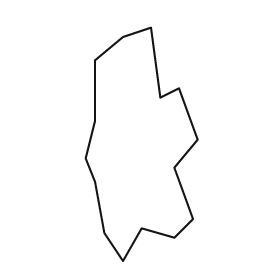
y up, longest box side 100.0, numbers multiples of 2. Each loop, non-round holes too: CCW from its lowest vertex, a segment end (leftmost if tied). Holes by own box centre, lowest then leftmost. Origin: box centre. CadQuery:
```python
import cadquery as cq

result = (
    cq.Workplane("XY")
    .moveTo(-8.0, -50.0)
    .lineTo(0.0, -36.0)
    .lineTo(14.0, -40.0)
    .lineTo(22.0, -32.0)
    .lineTo(14.0, -10.0)
    .lineTo(24.0, 2.0)
    .lineTo(16.0, 24.0)
    .lineTo(8.0, 20.0)
    .lineTo(4.0, 50.0)
    .lineTo(-8.0, 46.0)
    .lineTo(-20.0, 36.0)
    .lineTo(-20.0, 10.0)
    .lineTo(-24.0, -6.0)
    .lineTo(-20.0, -16.0)
    .lineTo(-16.0, -38.0)
    .close()
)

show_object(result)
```